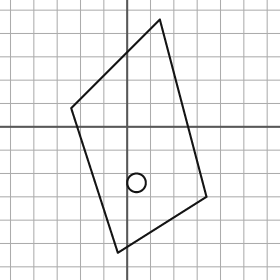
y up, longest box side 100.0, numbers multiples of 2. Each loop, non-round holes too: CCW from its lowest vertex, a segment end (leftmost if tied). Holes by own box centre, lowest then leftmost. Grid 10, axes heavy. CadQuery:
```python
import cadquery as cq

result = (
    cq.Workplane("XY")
    .moveTo(-4.0, -54.0)
    .lineTo(34.0, -30.0)
    .lineTo(14.0, 46.0)
    .lineTo(-24.0, 8.0)
    .close()
    .moveTo(4.0, -24.0)
    .circle(4.0)
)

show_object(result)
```